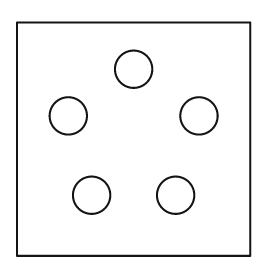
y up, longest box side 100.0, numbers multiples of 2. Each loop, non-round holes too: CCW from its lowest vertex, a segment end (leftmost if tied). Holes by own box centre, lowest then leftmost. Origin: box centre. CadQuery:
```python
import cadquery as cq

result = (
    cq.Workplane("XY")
    .moveTo(-50.0, -50.0)
    .lineTo(50.0, -50.0)
    .lineTo(50.0, 50.0)
    .lineTo(-50.0, 50.0)
    .close()
    .moveTo(-18.0, -24.0)
    .circle(8.0)
    .moveTo(18.0, -24.0)
    .circle(8.0)
    .moveTo(-28.0, 10.0)
    .circle(8.0)
    .moveTo(28.0, 10.0)
    .circle(8.0)
    .moveTo(0.0, 30.0)
    .circle(8.0)
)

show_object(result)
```